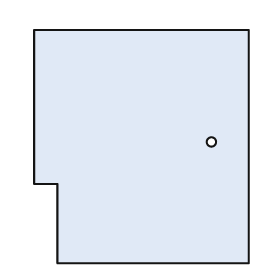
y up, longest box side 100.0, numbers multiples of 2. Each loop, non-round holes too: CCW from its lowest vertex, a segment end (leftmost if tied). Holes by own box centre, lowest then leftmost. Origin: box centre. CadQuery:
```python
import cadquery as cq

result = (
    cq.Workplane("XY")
    .moveTo(-36.0, -50.0)
    .lineTo(46.0, -50.0)
    .lineTo(46.0, 50.0)
    .lineTo(-46.0, 50.0)
    .lineTo(-46.0, -16.0)
    .lineTo(-36.0, -16.0)
    .close()
    .moveTo(30.0, 2.0)
    .circle(2.0)
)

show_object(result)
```